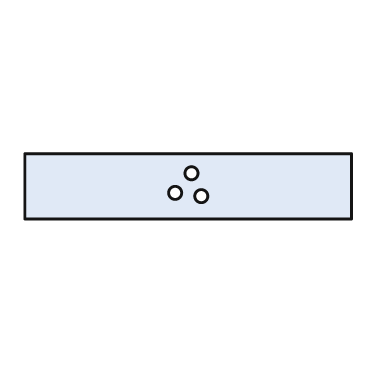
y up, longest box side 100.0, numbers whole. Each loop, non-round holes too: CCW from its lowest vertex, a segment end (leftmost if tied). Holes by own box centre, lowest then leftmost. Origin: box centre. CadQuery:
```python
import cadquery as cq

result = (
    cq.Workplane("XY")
    .moveTo(-50.0, -10.0)
    .lineTo(50.0, -10.0)
    .lineTo(50.0, 10.0)
    .lineTo(-50.0, 10.0)
    .close()
    .moveTo(4.0, -3.0)
    .circle(2.0)
    .moveTo(-4.0, -2.0)
    .circle(2.0)
    .moveTo(1.0, 4.0)
    .circle(2.0)
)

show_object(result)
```